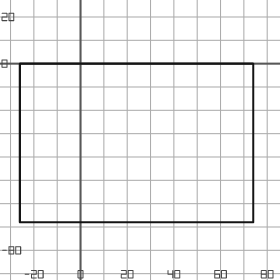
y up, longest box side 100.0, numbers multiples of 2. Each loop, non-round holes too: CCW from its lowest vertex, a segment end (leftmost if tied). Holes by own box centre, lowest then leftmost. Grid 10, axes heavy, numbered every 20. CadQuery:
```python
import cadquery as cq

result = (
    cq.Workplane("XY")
    .moveTo(-26.0, -68.0)
    .lineTo(74.0, -68.0)
    .lineTo(74.0, 0.0)
    .lineTo(-26.0, 0.0)
    .close()
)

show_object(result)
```